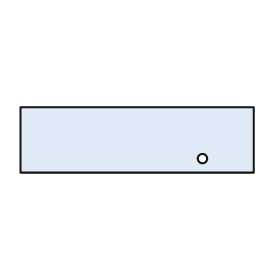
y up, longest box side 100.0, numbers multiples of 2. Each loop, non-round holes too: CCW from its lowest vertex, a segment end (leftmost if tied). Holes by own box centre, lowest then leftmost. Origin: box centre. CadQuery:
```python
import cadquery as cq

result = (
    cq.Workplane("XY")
    .moveTo(-50.0, -14.0)
    .lineTo(50.0, -14.0)
    .lineTo(50.0, 14.0)
    .lineTo(-50.0, 14.0)
    .close()
    .moveTo(28.0, -8.0)
    .circle(2.0)
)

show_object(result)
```